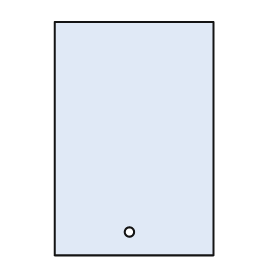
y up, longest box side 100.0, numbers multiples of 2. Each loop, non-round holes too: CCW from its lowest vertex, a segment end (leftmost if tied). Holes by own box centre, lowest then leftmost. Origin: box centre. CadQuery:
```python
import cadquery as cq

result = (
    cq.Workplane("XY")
    .moveTo(-34.0, -50.0)
    .lineTo(34.0, -50.0)
    .lineTo(34.0, 50.0)
    .lineTo(-34.0, 50.0)
    .close()
    .moveTo(-2.0, -40.0)
    .circle(2.0)
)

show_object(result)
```